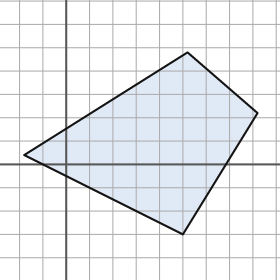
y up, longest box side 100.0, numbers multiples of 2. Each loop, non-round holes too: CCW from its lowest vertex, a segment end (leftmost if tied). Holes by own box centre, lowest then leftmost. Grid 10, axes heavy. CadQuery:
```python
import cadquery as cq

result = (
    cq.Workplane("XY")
    .moveTo(50.0, -30.0)
    .lineTo(82.0, 22.0)
    .lineTo(52.0, 48.0)
    .lineTo(-18.0, 4.0)
    .close()
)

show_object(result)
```